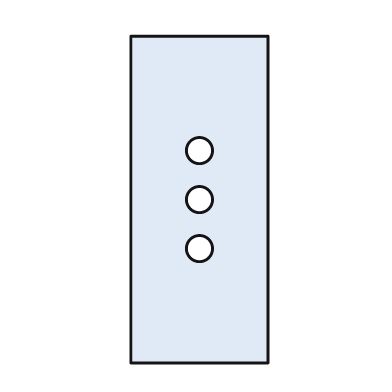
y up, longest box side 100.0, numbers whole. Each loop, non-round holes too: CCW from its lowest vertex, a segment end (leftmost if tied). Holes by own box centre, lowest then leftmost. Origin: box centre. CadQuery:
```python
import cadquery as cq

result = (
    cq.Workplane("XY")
    .moveTo(-21.0, -50.0)
    .lineTo(21.0, -50.0)
    .lineTo(21.0, 50.0)
    .lineTo(-21.0, 50.0)
    .close()
    .moveTo(0.0, -15.0)
    .circle(4.0)
    .moveTo(0.0, 0.0)
    .circle(4.0)
    .moveTo(0.0, 15.0)
    .circle(4.0)
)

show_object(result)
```